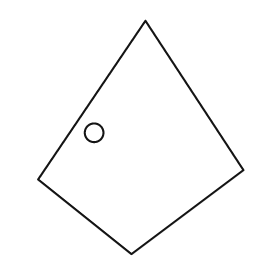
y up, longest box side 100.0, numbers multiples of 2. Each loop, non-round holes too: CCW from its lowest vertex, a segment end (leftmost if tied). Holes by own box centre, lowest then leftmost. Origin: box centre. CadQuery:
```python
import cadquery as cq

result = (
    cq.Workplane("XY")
    .moveTo(-4.0, -50.0)
    .lineTo(44.0, -14.0)
    .lineTo(2.0, 50.0)
    .lineTo(-44.0, -18.0)
    .close()
    .moveTo(-20.0, 2.0)
    .circle(4.0)
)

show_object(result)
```